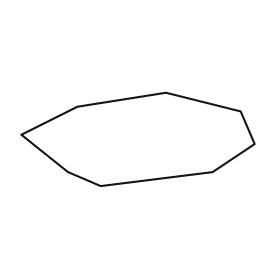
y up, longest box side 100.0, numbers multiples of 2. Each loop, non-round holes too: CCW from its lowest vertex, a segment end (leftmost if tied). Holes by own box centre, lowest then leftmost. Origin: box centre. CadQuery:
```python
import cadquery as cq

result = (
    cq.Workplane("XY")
    .moveTo(-16.0, -20.0)
    .lineTo(32.0, -14.0)
    .lineTo(50.0, -2.0)
    .lineTo(44.0, 12.0)
    .lineTo(12.0, 20.0)
    .lineTo(-26.0, 14.0)
    .lineTo(-50.0, 2.0)
    .lineTo(-30.0, -14.0)
    .close()
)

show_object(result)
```